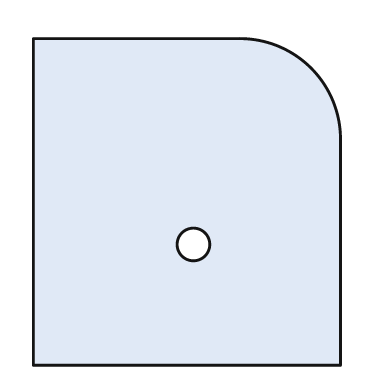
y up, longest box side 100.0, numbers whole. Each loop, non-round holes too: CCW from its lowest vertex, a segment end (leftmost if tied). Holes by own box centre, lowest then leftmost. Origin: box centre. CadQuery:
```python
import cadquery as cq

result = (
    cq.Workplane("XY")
    .moveTo(-47.0, -50.0)
    .lineTo(47.0, -50.0)
    .lineTo(47.0, 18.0)
    .threePointArc((38.0, 41.0), (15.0, 50.0))
    .lineTo(-47.0, 50.0)
    .close()
    .moveTo(2.0, -13.0)
    .circle(5.0)
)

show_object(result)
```